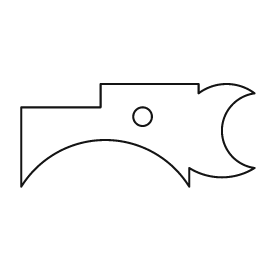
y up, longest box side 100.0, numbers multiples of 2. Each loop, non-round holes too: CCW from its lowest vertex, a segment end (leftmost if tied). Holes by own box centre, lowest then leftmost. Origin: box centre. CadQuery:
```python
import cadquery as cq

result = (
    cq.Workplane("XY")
    .moveTo(-50.0, -22.0)
    .threePointArc((-14.0, -2.0), (22.0, -22.0))
    .lineTo(22.0, -14.0)
    .threePointArc((36.0, -18.0), (50.0, -14.0))
    .threePointArc((36.0, 2.0), (50.0, 18.0))
    .threePointArc((38.0, 22.0), (26.0, 18.0))
    .lineTo(26.0, 22.0)
    .lineTo(-16.0, 22.0)
    .lineTo(-16.0, 12.0)
    .lineTo(-50.0, 12.0)
    .close()
    .moveTo(2.0, 8.0)
    .circle(4.0)
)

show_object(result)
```